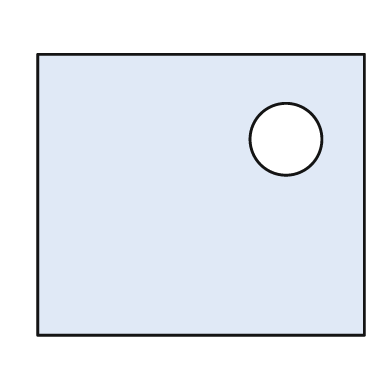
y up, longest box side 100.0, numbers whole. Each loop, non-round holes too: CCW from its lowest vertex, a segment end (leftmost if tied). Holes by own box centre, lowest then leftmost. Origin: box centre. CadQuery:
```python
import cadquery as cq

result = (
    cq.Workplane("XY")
    .moveTo(-50.0, -43.0)
    .lineTo(50.0, -43.0)
    .lineTo(50.0, 43.0)
    .lineTo(-50.0, 43.0)
    .close()
    .moveTo(26.0, 17.0)
    .circle(11.0)
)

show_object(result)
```